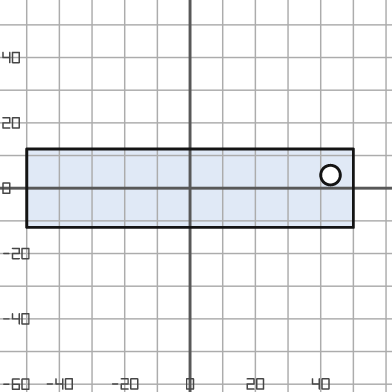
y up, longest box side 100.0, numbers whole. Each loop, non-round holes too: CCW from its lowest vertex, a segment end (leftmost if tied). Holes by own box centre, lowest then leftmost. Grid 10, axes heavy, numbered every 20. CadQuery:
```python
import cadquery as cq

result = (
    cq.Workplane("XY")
    .moveTo(-50.0, -12.0)
    .lineTo(50.0, -12.0)
    .lineTo(50.0, 12.0)
    .lineTo(-50.0, 12.0)
    .close()
    .moveTo(43.0, 4.0)
    .circle(3.0)
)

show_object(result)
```